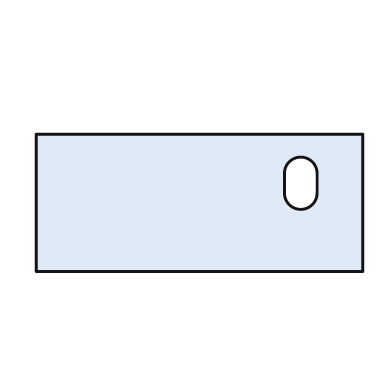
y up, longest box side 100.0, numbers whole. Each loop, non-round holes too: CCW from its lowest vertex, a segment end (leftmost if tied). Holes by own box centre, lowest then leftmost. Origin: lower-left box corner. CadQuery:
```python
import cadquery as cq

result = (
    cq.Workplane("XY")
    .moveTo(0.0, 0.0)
    .lineTo(100.0, 0.0)
    .lineTo(100.0, 42.0)
    .lineTo(0.0, 42.0)
    .close()
    .moveTo(76.0, 24.0)
    .threePointArc((81.0, 19.0), (86.0, 24.0))
    .lineTo(86.0, 30.0)
    .threePointArc((81.0, 35.0), (76.0, 30.0))
    .close()
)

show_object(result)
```